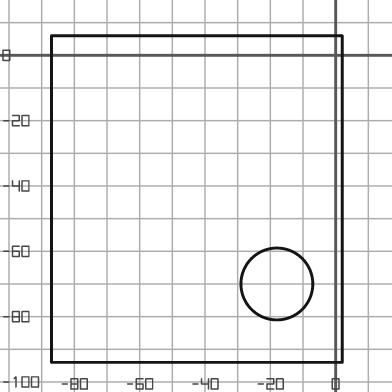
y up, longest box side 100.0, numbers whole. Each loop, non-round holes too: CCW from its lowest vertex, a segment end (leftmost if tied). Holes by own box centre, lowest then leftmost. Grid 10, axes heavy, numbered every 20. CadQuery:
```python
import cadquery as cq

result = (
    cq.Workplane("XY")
    .moveTo(-87.0, -94.0)
    .lineTo(2.0, -94.0)
    .lineTo(2.0, 6.0)
    .lineTo(-87.0, 6.0)
    .close()
    .moveTo(-18.0, -70.0)
    .circle(11.0)
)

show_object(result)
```